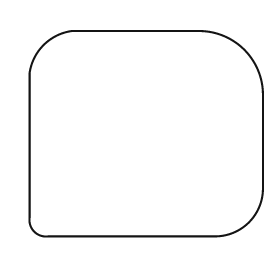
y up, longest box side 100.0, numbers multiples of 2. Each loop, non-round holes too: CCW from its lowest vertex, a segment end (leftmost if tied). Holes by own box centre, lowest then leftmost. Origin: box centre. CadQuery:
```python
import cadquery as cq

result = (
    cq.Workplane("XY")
    .moveTo(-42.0, -44.0)
    .lineTo(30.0, -44.0)
    .threePointArc((44.0, -38.0), (50.0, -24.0))
    .lineTo(50.0, 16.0)
    .threePointArc((42.0, 36.0), (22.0, 44.0))
    .lineTo(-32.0, 44.0)
    .threePointArc((-44.0, 38.0), (-50.0, 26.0))
    .lineTo(-50.0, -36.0)
    .threePointArc((-48.0, -42.0), (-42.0, -44.0))
    .close()
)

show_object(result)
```